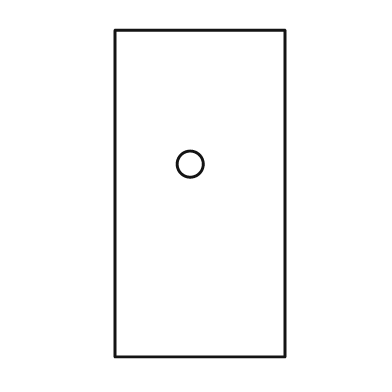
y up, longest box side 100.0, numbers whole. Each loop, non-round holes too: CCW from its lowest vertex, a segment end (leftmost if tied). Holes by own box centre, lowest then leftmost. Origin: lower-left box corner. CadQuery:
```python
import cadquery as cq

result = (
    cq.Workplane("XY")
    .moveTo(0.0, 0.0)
    .lineTo(52.0, 0.0)
    .lineTo(52.0, 100.0)
    .lineTo(0.0, 100.0)
    .close()
    .moveTo(23.0, 59.0)
    .circle(4.0)
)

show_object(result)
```